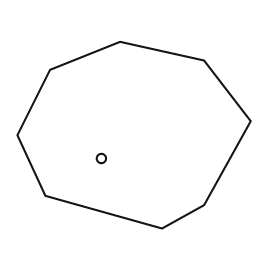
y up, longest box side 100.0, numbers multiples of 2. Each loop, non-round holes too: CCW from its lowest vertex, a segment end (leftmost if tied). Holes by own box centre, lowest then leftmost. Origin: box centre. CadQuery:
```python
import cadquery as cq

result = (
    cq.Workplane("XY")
    .moveTo(12.0, -40.0)
    .lineTo(30.0, -30.0)
    .lineTo(50.0, 6.0)
    .lineTo(30.0, 32.0)
    .lineTo(-6.0, 40.0)
    .lineTo(-36.0, 28.0)
    .lineTo(-50.0, 0.0)
    .lineTo(-38.0, -26.0)
    .close()
    .moveTo(-14.0, -10.0)
    .circle(2.0)
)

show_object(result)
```